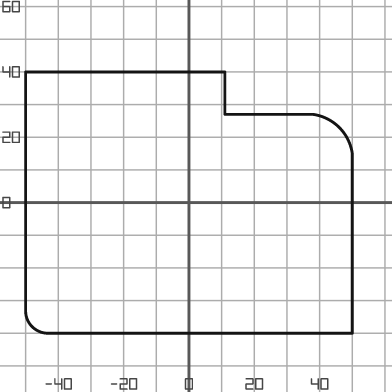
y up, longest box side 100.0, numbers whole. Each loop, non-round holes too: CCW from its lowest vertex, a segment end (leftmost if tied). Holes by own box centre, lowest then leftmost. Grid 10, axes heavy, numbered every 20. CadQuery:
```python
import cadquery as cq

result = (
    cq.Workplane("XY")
    .moveTo(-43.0, -40.0)
    .lineTo(50.0, -40.0)
    .lineTo(50.0, 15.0)
    .threePointArc((46.0, 23.0), (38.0, 27.0))
    .lineTo(11.0, 27.0)
    .lineTo(11.0, 40.0)
    .lineTo(-50.0, 40.0)
    .lineTo(-50.0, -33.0)
    .threePointArc((-48.0, -38.0), (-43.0, -40.0))
    .close()
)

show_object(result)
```